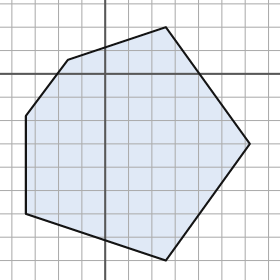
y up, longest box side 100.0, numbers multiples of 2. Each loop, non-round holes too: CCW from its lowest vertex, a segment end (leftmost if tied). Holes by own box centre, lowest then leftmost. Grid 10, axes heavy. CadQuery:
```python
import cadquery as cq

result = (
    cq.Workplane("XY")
    .moveTo(26.0, -80.0)
    .lineTo(62.0, -30.0)
    .lineTo(26.0, 20.0)
    .lineTo(-16.0, 6.0)
    .lineTo(-34.0, -18.0)
    .lineTo(-34.0, -60.0)
    .close()
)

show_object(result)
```